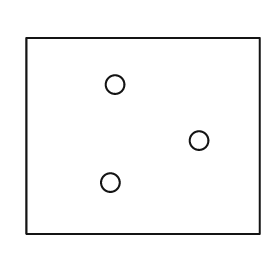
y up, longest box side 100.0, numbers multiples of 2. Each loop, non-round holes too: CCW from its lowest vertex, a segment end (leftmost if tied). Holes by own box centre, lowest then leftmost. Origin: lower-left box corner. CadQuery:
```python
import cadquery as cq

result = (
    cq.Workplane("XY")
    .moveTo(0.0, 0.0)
    .lineTo(100.0, 0.0)
    .lineTo(100.0, 84.0)
    .lineTo(0.0, 84.0)
    .close()
    .moveTo(36.0, 22.0)
    .circle(4.0)
    .moveTo(74.0, 40.0)
    .circle(4.0)
    .moveTo(38.0, 64.0)
    .circle(4.0)
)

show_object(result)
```